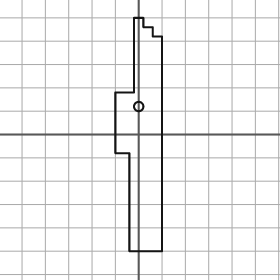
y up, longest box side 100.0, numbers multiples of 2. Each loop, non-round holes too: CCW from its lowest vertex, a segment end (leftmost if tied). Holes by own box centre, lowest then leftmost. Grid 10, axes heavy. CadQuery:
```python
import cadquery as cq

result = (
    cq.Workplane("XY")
    .moveTo(-4.0, -50.0)
    .lineTo(10.0, -50.0)
    .lineTo(10.0, 42.0)
    .lineTo(6.0, 42.0)
    .lineTo(6.0, 46.0)
    .lineTo(2.0, 46.0)
    .lineTo(2.0, 50.0)
    .lineTo(-2.0, 50.0)
    .lineTo(-2.0, 18.0)
    .lineTo(-10.0, 18.0)
    .lineTo(-10.0, -8.0)
    .lineTo(-4.0, -8.0)
    .close()
    .moveTo(0.0, 12.0)
    .circle(2.0)
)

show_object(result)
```